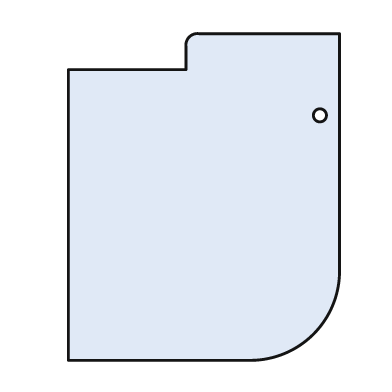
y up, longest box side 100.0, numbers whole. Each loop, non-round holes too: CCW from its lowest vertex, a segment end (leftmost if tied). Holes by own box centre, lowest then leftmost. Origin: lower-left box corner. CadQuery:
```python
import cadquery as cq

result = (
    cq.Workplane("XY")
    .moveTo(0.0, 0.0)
    .lineTo(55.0, 0.0)
    .threePointArc((75.0, 8.0), (83.0, 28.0))
    .lineTo(83.0, 100.0)
    .lineTo(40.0, 100.0)
    .threePointArc((37.0, 99.0), (36.0, 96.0))
    .lineTo(36.0, 89.0)
    .lineTo(0.0, 89.0)
    .close()
    .moveTo(77.0, 75.0)
    .circle(2.0)
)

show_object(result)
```